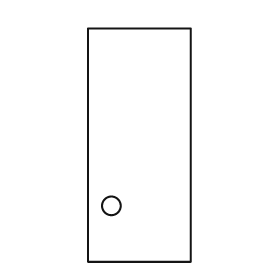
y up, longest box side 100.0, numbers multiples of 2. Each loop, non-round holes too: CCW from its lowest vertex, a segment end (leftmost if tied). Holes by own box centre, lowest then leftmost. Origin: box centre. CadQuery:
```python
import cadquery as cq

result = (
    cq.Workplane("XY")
    .moveTo(-22.0, -50.0)
    .lineTo(22.0, -50.0)
    .lineTo(22.0, 50.0)
    .lineTo(-22.0, 50.0)
    .close()
    .moveTo(-12.0, -26.0)
    .circle(4.0)
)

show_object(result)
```